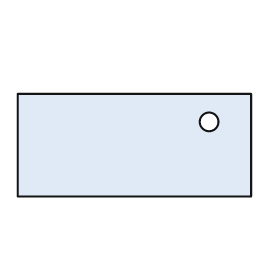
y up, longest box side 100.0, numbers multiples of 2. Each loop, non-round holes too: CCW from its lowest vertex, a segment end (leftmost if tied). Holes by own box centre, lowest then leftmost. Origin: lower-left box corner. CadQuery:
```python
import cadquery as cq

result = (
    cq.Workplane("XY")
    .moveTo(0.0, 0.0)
    .lineTo(100.0, 0.0)
    .lineTo(100.0, 44.0)
    .lineTo(0.0, 44.0)
    .close()
    .moveTo(82.0, 32.0)
    .circle(4.0)
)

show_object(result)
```